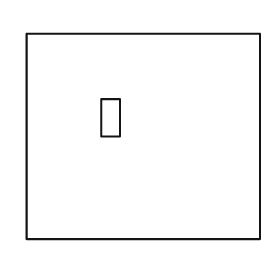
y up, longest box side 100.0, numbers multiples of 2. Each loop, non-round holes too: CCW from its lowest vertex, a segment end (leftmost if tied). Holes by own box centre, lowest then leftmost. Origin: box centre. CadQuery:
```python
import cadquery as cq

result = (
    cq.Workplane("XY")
    .moveTo(-50.0, -44.0)
    .lineTo(50.0, -44.0)
    .lineTo(50.0, 44.0)
    .lineTo(-50.0, 44.0)
    .close()
    .moveTo(-18.0, 0.0)
    .lineTo(-10.0, 0.0)
    .lineTo(-10.0, 16.0)
    .lineTo(-18.0, 16.0)
    .close()
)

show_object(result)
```